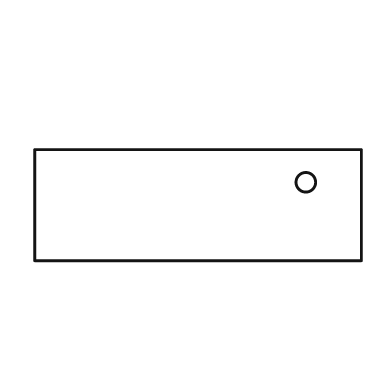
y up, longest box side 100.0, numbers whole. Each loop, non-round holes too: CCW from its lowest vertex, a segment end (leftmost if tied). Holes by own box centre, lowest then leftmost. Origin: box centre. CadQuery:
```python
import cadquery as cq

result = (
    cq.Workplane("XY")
    .moveTo(-50.0, -17.0)
    .lineTo(50.0, -17.0)
    .lineTo(50.0, 17.0)
    .lineTo(-50.0, 17.0)
    .close()
    .moveTo(33.0, 7.0)
    .circle(3.0)
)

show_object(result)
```